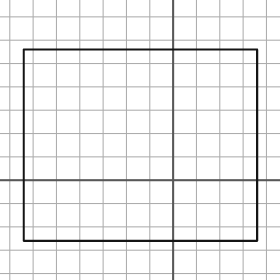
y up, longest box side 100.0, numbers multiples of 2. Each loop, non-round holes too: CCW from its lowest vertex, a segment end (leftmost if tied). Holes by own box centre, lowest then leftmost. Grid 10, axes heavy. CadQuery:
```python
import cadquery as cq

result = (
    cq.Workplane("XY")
    .moveTo(-64.0, -26.0)
    .lineTo(36.0, -26.0)
    .lineTo(36.0, 56.0)
    .lineTo(-64.0, 56.0)
    .close()
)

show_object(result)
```